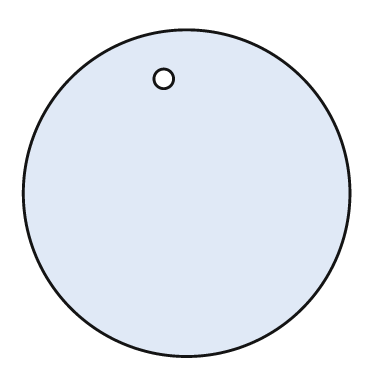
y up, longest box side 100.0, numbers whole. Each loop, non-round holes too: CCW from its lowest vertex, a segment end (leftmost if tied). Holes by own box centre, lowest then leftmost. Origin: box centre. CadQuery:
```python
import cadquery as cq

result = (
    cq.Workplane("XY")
    .moveTo(0.0, 0.0)
    .circle(50.0)
    .moveTo(-7.0, 35.0)
    .circle(3.0)
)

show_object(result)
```